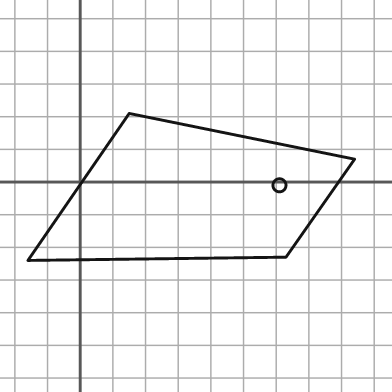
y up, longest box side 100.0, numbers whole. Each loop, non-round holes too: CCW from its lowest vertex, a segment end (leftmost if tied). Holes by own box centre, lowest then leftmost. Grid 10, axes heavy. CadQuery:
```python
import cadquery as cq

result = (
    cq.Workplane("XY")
    .moveTo(-16.0, -24.0)
    .lineTo(63.0, -23.0)
    .lineTo(84.0, 7.0)
    .lineTo(15.0, 21.0)
    .close()
    .moveTo(61.0, -1.0)
    .circle(2.0)
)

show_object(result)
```